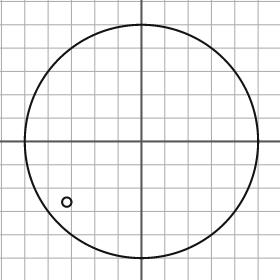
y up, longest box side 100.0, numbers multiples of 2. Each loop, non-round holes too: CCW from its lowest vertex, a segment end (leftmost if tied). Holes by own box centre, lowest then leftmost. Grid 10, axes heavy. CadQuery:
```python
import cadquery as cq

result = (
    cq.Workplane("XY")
    .moveTo(0.0, 0.0)
    .circle(50.0)
    .moveTo(-32.0, -26.0)
    .circle(2.0)
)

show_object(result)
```